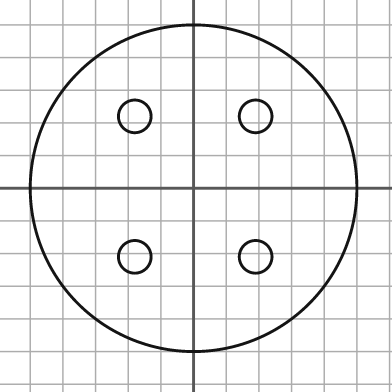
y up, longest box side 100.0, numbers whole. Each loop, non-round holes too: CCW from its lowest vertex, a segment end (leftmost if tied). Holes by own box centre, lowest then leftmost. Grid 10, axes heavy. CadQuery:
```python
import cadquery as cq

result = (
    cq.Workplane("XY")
    .moveTo(0.0, 0.0)
    .circle(50.0)
    .moveTo(-18.0, -21.0)
    .circle(5.0)
    .moveTo(19.0, -21.0)
    .circle(5.0)
    .moveTo(-18.0, 22.0)
    .circle(5.0)
    .moveTo(19.0, 22.0)
    .circle(5.0)
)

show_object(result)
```